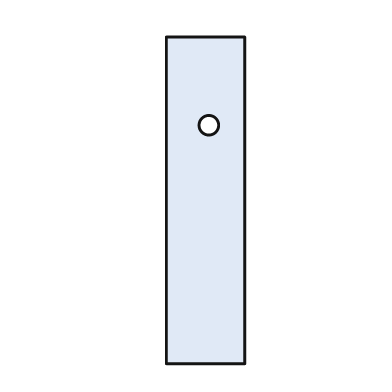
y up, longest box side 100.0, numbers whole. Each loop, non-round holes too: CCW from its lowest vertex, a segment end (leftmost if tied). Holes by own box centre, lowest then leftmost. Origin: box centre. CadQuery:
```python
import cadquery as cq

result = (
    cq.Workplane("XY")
    .moveTo(-12.0, -50.0)
    .lineTo(12.0, -50.0)
    .lineTo(12.0, 50.0)
    .lineTo(-12.0, 50.0)
    .close()
    .moveTo(1.0, 23.0)
    .circle(3.0)
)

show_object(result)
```